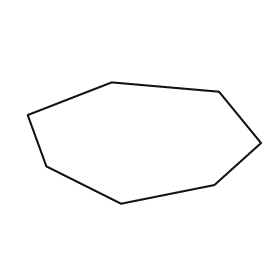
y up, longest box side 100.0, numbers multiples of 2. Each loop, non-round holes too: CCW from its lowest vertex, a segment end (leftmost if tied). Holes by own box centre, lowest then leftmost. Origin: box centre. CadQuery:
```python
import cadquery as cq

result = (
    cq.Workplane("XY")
    .moveTo(-10.0, -26.0)
    .lineTo(30.0, -18.0)
    .lineTo(50.0, 0.0)
    .lineTo(32.0, 22.0)
    .lineTo(-14.0, 26.0)
    .lineTo(-50.0, 12.0)
    .lineTo(-42.0, -10.0)
    .close()
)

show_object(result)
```